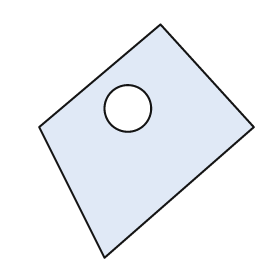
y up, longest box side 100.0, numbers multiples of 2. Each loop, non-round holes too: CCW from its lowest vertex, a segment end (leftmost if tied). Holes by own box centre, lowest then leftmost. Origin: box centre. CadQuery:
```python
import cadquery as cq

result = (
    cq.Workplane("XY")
    .moveTo(-18.0, -50.0)
    .lineTo(46.0, 6.0)
    .lineTo(6.0, 50.0)
    .lineTo(-46.0, 6.0)
    .close()
    .moveTo(-8.0, 14.0)
    .circle(10.0)
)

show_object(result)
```